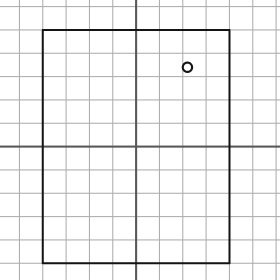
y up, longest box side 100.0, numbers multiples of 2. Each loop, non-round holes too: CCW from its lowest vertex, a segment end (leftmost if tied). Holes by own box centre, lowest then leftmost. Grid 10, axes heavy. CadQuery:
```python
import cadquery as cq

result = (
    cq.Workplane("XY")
    .moveTo(-40.0, -50.0)
    .lineTo(40.0, -50.0)
    .lineTo(40.0, 50.0)
    .lineTo(-40.0, 50.0)
    .close()
    .moveTo(22.0, 34.0)
    .circle(2.0)
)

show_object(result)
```